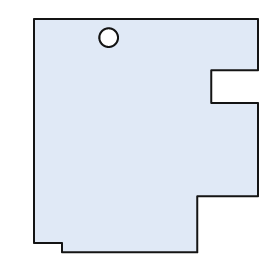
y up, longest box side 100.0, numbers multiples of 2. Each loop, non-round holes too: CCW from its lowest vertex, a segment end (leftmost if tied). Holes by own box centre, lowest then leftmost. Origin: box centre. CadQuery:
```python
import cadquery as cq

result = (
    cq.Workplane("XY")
    .moveTo(-36.0, -50.0)
    .lineTo(22.0, -50.0)
    .lineTo(22.0, -26.0)
    .lineTo(48.0, -26.0)
    .lineTo(48.0, 14.0)
    .lineTo(28.0, 14.0)
    .lineTo(28.0, 28.0)
    .lineTo(48.0, 28.0)
    .lineTo(48.0, 50.0)
    .lineTo(-48.0, 50.0)
    .lineTo(-48.0, -46.0)
    .lineTo(-36.0, -46.0)
    .close()
    .moveTo(-16.0, 42.0)
    .circle(4.0)
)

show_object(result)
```